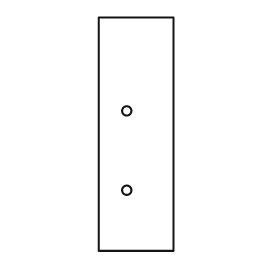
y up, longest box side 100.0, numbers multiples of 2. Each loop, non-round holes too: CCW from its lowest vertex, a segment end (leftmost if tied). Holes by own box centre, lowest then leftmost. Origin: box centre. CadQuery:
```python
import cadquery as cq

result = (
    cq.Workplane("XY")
    .moveTo(-16.0, -50.0)
    .lineTo(16.0, -50.0)
    .lineTo(16.0, 50.0)
    .lineTo(-16.0, 50.0)
    .close()
    .moveTo(-4.0, -24.0)
    .circle(2.0)
    .moveTo(-4.0, 10.0)
    .circle(2.0)
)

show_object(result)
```